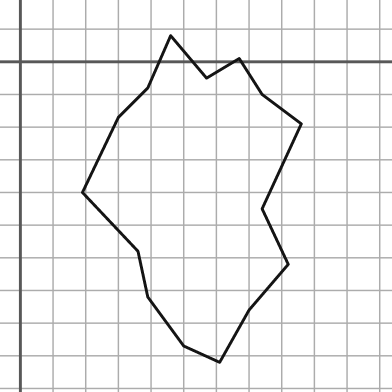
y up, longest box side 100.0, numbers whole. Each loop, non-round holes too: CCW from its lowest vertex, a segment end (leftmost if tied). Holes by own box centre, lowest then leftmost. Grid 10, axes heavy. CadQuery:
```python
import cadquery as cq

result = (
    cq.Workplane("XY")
    .moveTo(61.0, -92.0)
    .lineTo(70.0, -76.0)
    .lineTo(82.0, -62.0)
    .lineTo(74.0, -45.0)
    .lineTo(86.0, -19.0)
    .lineTo(74.0, -10.0)
    .lineTo(67.0, 1.0)
    .lineTo(57.0, -5.0)
    .lineTo(46.0, 8.0)
    .lineTo(39.0, -8.0)
    .lineTo(30.0, -17.0)
    .lineTo(19.0, -40.0)
    .lineTo(36.0, -58.0)
    .lineTo(39.0, -72.0)
    .lineTo(50.0, -87.0)
    .close()
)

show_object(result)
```